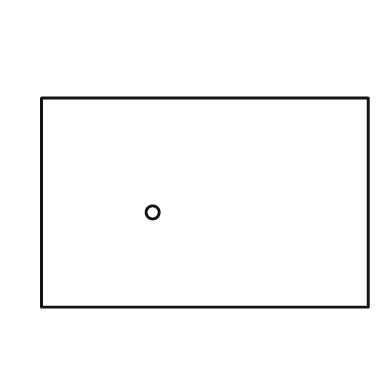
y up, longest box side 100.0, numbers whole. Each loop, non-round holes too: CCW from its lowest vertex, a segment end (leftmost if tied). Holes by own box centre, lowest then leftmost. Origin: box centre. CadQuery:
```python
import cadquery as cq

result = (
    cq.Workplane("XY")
    .moveTo(-50.0, -32.0)
    .lineTo(50.0, -32.0)
    .lineTo(50.0, 32.0)
    .lineTo(-50.0, 32.0)
    .close()
    .moveTo(-16.0, -3.0)
    .circle(2.0)
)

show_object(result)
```